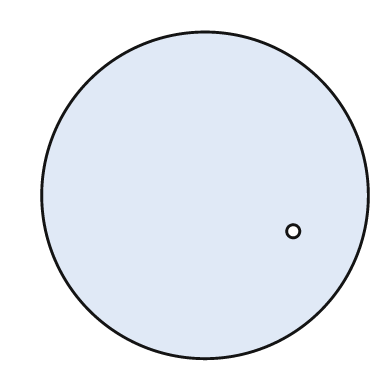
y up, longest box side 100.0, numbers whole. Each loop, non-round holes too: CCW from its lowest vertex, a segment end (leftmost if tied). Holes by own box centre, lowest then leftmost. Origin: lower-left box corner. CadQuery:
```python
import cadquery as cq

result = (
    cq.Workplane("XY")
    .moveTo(50.0, 50.0)
    .circle(50.0)
    .moveTo(77.0, 39.0)
    .circle(2.0)
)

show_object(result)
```